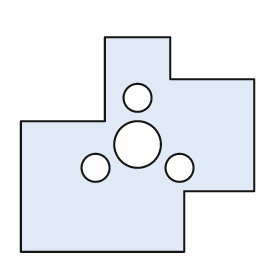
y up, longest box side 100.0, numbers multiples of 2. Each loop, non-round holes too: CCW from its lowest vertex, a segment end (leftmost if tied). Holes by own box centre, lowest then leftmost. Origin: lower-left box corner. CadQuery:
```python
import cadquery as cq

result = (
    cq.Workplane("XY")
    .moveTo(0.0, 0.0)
    .lineTo(70.0, 0.0)
    .lineTo(70.0, 26.0)
    .lineTo(100.0, 26.0)
    .lineTo(100.0, 74.0)
    .lineTo(64.0, 74.0)
    .lineTo(64.0, 92.0)
    .lineTo(36.0, 92.0)
    .lineTo(36.0, 56.0)
    .lineTo(0.0, 56.0)
    .close()
    .moveTo(32.0, 36.0)
    .circle(6.0)
    .moveTo(68.0, 36.0)
    .circle(6.0)
    .moveTo(50.0, 46.0)
    .circle(10.0)
    .moveTo(50.0, 66.0)
    .circle(6.0)
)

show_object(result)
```